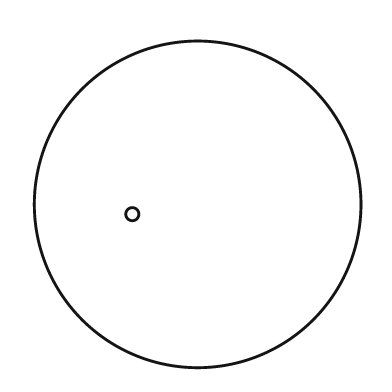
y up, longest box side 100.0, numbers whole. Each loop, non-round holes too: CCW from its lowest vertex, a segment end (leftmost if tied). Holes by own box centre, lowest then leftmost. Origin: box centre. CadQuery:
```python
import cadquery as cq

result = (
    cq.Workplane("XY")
    .moveTo(0.0, 0.0)
    .circle(50.0)
    .moveTo(-20.0, -3.0)
    .circle(2.0)
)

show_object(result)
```